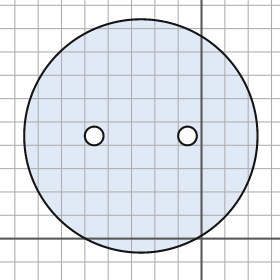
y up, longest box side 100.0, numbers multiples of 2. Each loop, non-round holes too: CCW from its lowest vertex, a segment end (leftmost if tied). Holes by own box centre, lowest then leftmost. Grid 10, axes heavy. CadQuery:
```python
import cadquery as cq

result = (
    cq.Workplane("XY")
    .moveTo(-26.0, 44.0)
    .circle(50.0)
    .moveTo(-46.0, 44.0)
    .circle(4.0)
    .moveTo(-6.0, 44.0)
    .circle(4.0)
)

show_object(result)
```